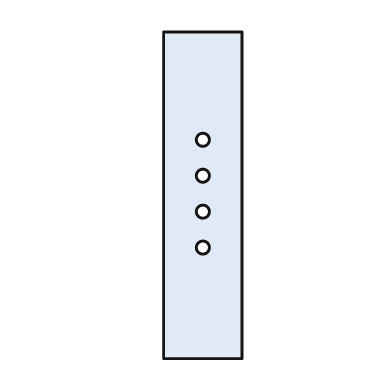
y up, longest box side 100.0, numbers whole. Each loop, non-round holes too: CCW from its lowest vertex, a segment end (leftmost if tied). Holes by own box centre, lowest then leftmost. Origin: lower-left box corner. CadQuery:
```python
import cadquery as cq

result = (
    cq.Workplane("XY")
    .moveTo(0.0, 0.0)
    .lineTo(24.0, 0.0)
    .lineTo(24.0, 100.0)
    .lineTo(0.0, 100.0)
    .close()
    .moveTo(12.0, 34.0)
    .circle(2.0)
    .moveTo(12.0, 45.0)
    .circle(2.0)
    .moveTo(12.0, 56.0)
    .circle(2.0)
    .moveTo(12.0, 67.0)
    .circle(2.0)
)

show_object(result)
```